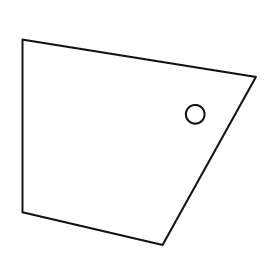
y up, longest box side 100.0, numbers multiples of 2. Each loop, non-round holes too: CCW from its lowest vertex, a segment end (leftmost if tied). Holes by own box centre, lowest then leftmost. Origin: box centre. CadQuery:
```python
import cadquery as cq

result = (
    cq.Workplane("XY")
    .moveTo(10.0, -44.0)
    .lineTo(50.0, 28.0)
    .lineTo(-50.0, 44.0)
    .lineTo(-50.0, -30.0)
    .close()
    .moveTo(24.0, 12.0)
    .circle(4.0)
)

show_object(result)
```